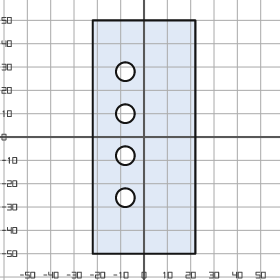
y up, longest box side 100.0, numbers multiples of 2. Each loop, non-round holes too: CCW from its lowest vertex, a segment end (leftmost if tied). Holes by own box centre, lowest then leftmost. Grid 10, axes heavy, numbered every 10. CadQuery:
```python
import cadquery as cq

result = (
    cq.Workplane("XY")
    .moveTo(-22.0, -50.0)
    .lineTo(22.0, -50.0)
    .lineTo(22.0, 50.0)
    .lineTo(-22.0, 50.0)
    .close()
    .moveTo(-8.0, -26.0)
    .circle(4.0)
    .moveTo(-8.0, -8.0)
    .circle(4.0)
    .moveTo(-8.0, 10.0)
    .circle(4.0)
    .moveTo(-8.0, 28.0)
    .circle(4.0)
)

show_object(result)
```